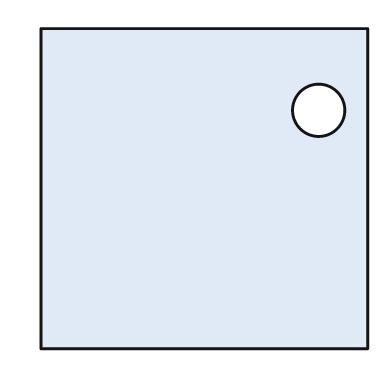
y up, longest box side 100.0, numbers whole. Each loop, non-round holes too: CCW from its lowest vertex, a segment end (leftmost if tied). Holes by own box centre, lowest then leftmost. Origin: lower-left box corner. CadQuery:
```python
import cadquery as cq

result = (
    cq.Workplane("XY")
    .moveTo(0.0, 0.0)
    .lineTo(100.0, 0.0)
    .lineTo(100.0, 98.0)
    .lineTo(0.0, 98.0)
    .close()
    .moveTo(85.0, 73.0)
    .circle(8.0)
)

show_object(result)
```